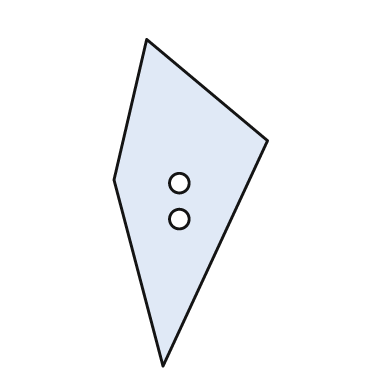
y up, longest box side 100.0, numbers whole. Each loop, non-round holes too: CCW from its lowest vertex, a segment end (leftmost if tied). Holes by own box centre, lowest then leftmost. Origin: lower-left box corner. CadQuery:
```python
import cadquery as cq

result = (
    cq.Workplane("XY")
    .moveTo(15.0, 0.0)
    .lineTo(47.0, 69.0)
    .lineTo(10.0, 100.0)
    .lineTo(0.0, 57.0)
    .close()
    .moveTo(20.0, 45.0)
    .circle(3.0)
    .moveTo(20.0, 56.0)
    .circle(3.0)
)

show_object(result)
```